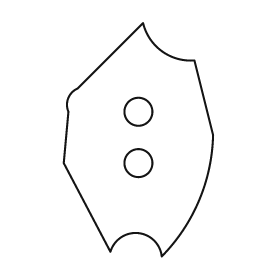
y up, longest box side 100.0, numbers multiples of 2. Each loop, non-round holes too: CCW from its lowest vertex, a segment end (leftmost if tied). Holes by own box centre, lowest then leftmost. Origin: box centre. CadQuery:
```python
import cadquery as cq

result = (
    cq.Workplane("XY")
    .moveTo(10.0, -50.0)
    .threePointArc((26.0, -26.0), (32.0, 2.0))
    .lineTo(24.0, 34.0)
    .threePointArc((10.0, 38.0), (2.0, 50.0))
    .lineTo(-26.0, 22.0)
    .threePointArc((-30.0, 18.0), (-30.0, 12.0))
    .lineTo(-32.0, -10.0)
    .lineTo(-12.0, -48.0)
    .threePointArc((0.0, -40.0), (10.0, -50.0))
    .close()
    .moveTo(0.0, -10.0)
    .circle(6.0)
    .moveTo(0.0, 12.0)
    .circle(6.0)
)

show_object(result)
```